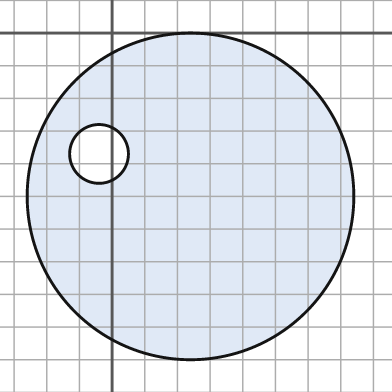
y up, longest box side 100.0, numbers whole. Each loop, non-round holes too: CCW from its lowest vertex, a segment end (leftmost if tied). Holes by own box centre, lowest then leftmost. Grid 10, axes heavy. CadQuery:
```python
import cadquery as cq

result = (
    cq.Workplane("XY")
    .moveTo(24.0, -50.0)
    .circle(50.0)
    .moveTo(-4.0, -37.0)
    .circle(9.0)
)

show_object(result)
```